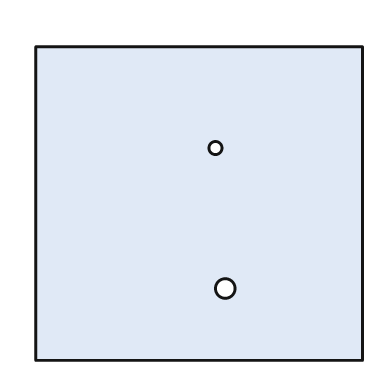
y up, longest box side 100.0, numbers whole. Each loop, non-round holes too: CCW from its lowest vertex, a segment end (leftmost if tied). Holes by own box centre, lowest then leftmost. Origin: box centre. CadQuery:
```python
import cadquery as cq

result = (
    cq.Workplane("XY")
    .moveTo(-50.0, -48.0)
    .lineTo(50.0, -48.0)
    .lineTo(50.0, 48.0)
    .lineTo(-50.0, 48.0)
    .close()
    .moveTo(8.0, -26.0)
    .circle(3.0)
    .moveTo(5.0, 17.0)
    .circle(2.0)
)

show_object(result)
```